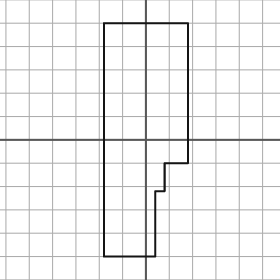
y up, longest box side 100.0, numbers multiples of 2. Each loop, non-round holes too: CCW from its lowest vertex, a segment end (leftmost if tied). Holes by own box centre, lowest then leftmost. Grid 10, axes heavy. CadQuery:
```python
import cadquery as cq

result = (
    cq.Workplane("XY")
    .moveTo(-18.0, -50.0)
    .lineTo(4.0, -50.0)
    .lineTo(4.0, -22.0)
    .lineTo(8.0, -22.0)
    .lineTo(8.0, -10.0)
    .lineTo(18.0, -10.0)
    .lineTo(18.0, 50.0)
    .lineTo(-18.0, 50.0)
    .close()
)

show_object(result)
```